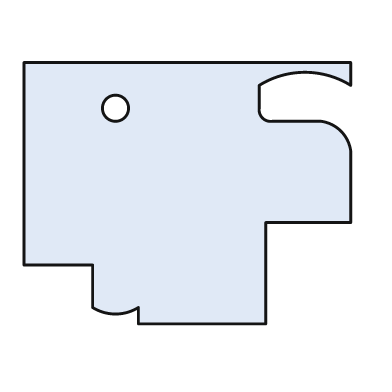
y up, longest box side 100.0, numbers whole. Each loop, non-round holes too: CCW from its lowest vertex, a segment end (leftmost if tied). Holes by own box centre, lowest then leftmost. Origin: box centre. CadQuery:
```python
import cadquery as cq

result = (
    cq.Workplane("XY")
    .moveTo(-15.0, -40.0)
    .lineTo(24.0, -40.0)
    .lineTo(24.0, -9.0)
    .lineTo(50.0, -9.0)
    .lineTo(50.0, 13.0)
    .threePointArc((47.0, 19.0), (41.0, 22.0))
    .lineTo(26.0, 22.0)
    .threePointArc((23.0, 23.0), (22.0, 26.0))
    .lineTo(22.0, 33.0)
    .threePointArc((36.0, 37.0), (50.0, 33.0))
    .lineTo(50.0, 40.0)
    .lineTo(-50.0, 40.0)
    .lineTo(-50.0, -22.0)
    .lineTo(-29.0, -22.0)
    .lineTo(-29.0, -35.0)
    .threePointArc((-22.0, -37.0), (-15.0, -35.0))
    .close()
    .moveTo(-22.0, 26.0)
    .circle(4.0)
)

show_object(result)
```